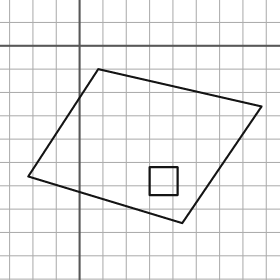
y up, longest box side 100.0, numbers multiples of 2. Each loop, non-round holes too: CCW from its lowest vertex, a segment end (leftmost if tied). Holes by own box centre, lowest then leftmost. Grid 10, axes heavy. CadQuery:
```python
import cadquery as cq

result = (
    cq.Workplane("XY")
    .moveTo(44.0, -76.0)
    .lineTo(78.0, -26.0)
    .lineTo(8.0, -10.0)
    .lineTo(-22.0, -56.0)
    .close()
    .moveTo(30.0, -64.0)
    .lineTo(42.0, -64.0)
    .lineTo(42.0, -52.0)
    .lineTo(30.0, -52.0)
    .close()
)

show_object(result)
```